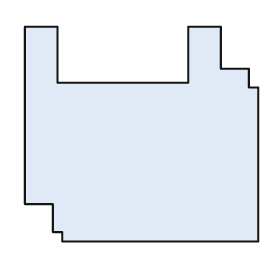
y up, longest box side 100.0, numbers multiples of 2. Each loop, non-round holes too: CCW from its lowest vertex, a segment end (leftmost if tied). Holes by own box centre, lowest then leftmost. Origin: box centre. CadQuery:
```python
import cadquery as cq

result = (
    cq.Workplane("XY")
    .moveTo(-34.0, -46.0)
    .lineTo(50.0, -46.0)
    .lineTo(50.0, 20.0)
    .lineTo(46.0, 20.0)
    .lineTo(46.0, 28.0)
    .lineTo(34.0, 28.0)
    .lineTo(34.0, 46.0)
    .lineTo(20.0, 46.0)
    .lineTo(20.0, 22.0)
    .lineTo(-36.0, 22.0)
    .lineTo(-36.0, 46.0)
    .lineTo(-50.0, 46.0)
    .lineTo(-50.0, -30.0)
    .lineTo(-38.0, -30.0)
    .lineTo(-38.0, -42.0)
    .lineTo(-34.0, -42.0)
    .close()
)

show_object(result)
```